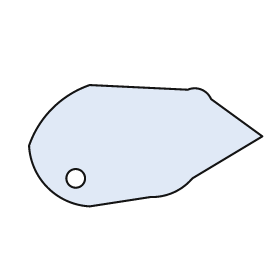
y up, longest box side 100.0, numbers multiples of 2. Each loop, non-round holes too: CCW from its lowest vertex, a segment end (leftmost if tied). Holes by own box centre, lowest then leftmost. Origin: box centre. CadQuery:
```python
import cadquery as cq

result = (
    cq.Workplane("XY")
    .moveTo(-24.0, -26.0)
    .lineTo(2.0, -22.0)
    .threePointArc((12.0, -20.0), (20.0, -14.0))
    .lineTo(50.0, 4.0)
    .lineTo(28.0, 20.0)
    .threePointArc((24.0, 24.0), (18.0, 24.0))
    .lineTo(-24.0, 26.0)
    .threePointArc((-40.0, 16.0), (-50.0, 0.0))
    .threePointArc((-42.0, -18.0), (-24.0, -26.0))
    .close()
    .moveTo(-30.0, -14.0)
    .circle(4.0)
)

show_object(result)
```